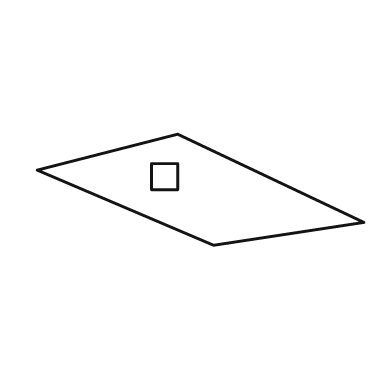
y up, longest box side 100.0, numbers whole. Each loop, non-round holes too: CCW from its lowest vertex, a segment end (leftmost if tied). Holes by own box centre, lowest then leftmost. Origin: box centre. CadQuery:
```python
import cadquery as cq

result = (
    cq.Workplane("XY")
    .moveTo(4.0, -17.0)
    .lineTo(50.0, -10.0)
    .lineTo(-7.0, 17.0)
    .lineTo(-50.0, 6.0)
    .close()
    .moveTo(-15.0, 0.0)
    .lineTo(-7.0, 0.0)
    .lineTo(-7.0, 8.0)
    .lineTo(-15.0, 8.0)
    .close()
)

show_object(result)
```